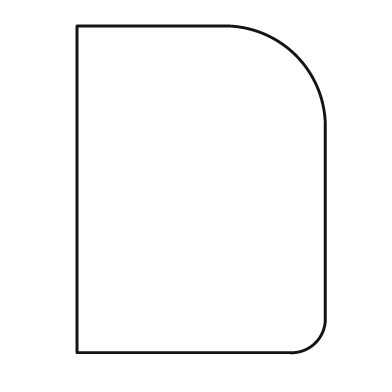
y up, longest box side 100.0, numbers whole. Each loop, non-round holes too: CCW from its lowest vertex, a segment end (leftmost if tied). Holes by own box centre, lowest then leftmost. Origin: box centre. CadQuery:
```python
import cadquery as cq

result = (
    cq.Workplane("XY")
    .moveTo(-38.0, -50.0)
    .lineTo(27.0, -50.0)
    .threePointArc((35.0, -47.0), (38.0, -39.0))
    .lineTo(38.0, 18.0)
    .threePointArc((29.0, 41.0), (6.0, 50.0))
    .lineTo(-38.0, 50.0)
    .close()
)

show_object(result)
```